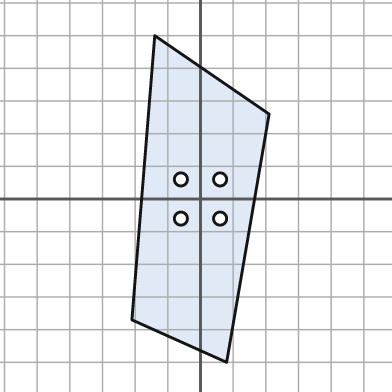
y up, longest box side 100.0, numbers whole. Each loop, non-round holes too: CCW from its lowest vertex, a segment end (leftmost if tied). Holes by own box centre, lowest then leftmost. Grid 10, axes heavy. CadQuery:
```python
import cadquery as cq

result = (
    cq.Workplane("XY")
    .moveTo(8.0, -50.0)
    .lineTo(21.0, 26.0)
    .lineTo(-14.0, 50.0)
    .lineTo(-21.0, -37.0)
    .close()
    .moveTo(-6.0, -6.0)
    .circle(2.0)
    .moveTo(6.0, -6.0)
    .circle(2.0)
    .moveTo(-6.0, 6.0)
    .circle(2.0)
    .moveTo(6.0, 6.0)
    .circle(2.0)
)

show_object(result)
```